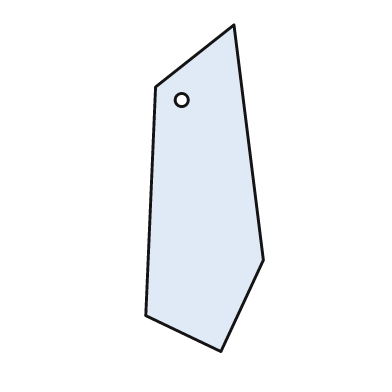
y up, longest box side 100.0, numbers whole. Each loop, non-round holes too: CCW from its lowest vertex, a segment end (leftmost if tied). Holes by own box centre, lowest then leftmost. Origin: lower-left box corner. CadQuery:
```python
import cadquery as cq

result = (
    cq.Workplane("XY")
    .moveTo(23.0, 0.0)
    .lineTo(36.0, 28.0)
    .lineTo(27.0, 100.0)
    .lineTo(3.0, 81.0)
    .lineTo(0.0, 11.0)
    .close()
    .moveTo(11.0, 77.0)
    .circle(2.0)
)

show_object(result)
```